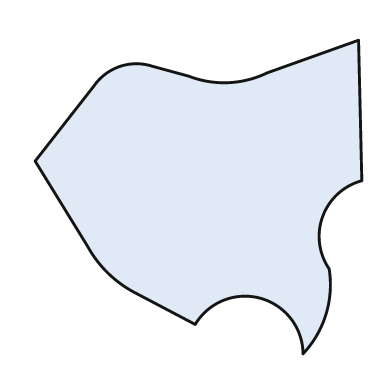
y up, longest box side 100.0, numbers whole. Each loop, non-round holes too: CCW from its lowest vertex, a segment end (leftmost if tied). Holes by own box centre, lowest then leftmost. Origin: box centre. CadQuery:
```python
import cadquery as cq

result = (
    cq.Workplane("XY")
    .moveTo(32.0, -48.0)
    .threePointArc((39.0, -36.0), (40.0, -22.0))
    .threePointArc((38.0, -6.0), (50.0, 5.0))
    .lineTo(49.0, 48.0)
    .lineTo(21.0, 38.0)
    .threePointArc((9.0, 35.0), (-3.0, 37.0))
    .lineTo(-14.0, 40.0)
    .threePointArc((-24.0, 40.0), (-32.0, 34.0))
    .lineTo(-50.0, 11.0)
    .lineTo(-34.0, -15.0)
    .threePointArc((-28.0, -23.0), (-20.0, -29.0))
    .lineTo(-1.0, -39.0)
    .threePointArc((19.0, -31.0), (32.0, -48.0))
    .close()
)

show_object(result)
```